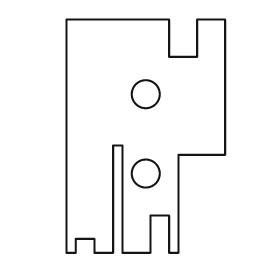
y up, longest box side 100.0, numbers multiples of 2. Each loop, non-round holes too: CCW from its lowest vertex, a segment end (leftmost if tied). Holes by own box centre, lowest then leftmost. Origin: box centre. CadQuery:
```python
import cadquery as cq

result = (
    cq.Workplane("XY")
    .moveTo(-34.0, -50.0)
    .lineTo(-30.0, -50.0)
    .lineTo(-30.0, -44.0)
    .lineTo(-22.0, -44.0)
    .lineTo(-22.0, -50.0)
    .lineTo(-14.0, -50.0)
    .lineTo(-14.0, -4.0)
    .lineTo(-10.0, -4.0)
    .lineTo(-10.0, -50.0)
    .lineTo(2.0, -50.0)
    .lineTo(2.0, -34.0)
    .lineTo(10.0, -34.0)
    .lineTo(10.0, -50.0)
    .lineTo(14.0, -50.0)
    .lineTo(14.0, -8.0)
    .lineTo(34.0, -8.0)
    .lineTo(34.0, 50.0)
    .lineTo(22.0, 50.0)
    .lineTo(22.0, 34.0)
    .lineTo(10.0, 34.0)
    .lineTo(10.0, 50.0)
    .lineTo(-34.0, 50.0)
    .close()
    .moveTo(0.0, -16.0)
    .circle(6.0)
    .moveTo(0.0, 18.0)
    .circle(6.0)
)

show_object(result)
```